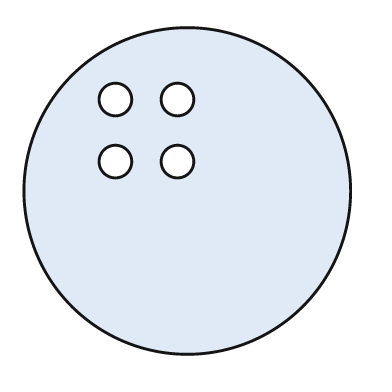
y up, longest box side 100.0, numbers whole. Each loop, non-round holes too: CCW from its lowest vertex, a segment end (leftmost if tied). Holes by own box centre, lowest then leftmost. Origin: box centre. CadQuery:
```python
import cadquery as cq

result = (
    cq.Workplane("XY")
    .moveTo(0.0, 0.0)
    .circle(50.0)
    .moveTo(-22.0, 9.0)
    .circle(5.0)
    .moveTo(-3.0, 9.0)
    .circle(5.0)
    .moveTo(-22.0, 28.0)
    .circle(5.0)
    .moveTo(-3.0, 28.0)
    .circle(5.0)
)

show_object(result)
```